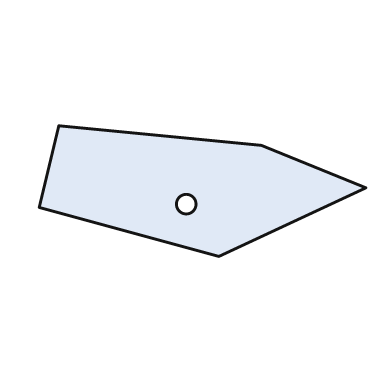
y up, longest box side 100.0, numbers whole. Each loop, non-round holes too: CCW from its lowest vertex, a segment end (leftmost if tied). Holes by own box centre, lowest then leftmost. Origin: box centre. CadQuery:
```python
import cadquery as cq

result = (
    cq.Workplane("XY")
    .moveTo(5.0, -20.0)
    .lineTo(50.0, 1.0)
    .lineTo(18.0, 14.0)
    .lineTo(-44.0, 20.0)
    .lineTo(-50.0, -5.0)
    .close()
    .moveTo(-5.0, -4.0)
    .circle(3.0)
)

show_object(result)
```